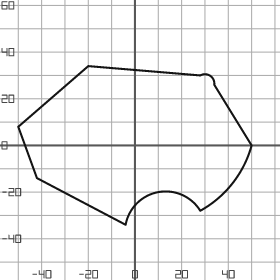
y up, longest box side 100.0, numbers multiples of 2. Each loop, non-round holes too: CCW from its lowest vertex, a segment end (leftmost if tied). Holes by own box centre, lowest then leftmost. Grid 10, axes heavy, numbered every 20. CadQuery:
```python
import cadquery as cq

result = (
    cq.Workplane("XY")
    .moveTo(-4.0, -34.0)
    .threePointArc((10.0, -20.0), (28.0, -28.0))
    .threePointArc((42.0, -16.0), (50.0, 0.0))
    .lineTo(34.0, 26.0)
    .threePointArc((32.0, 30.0), (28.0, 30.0))
    .lineTo(-20.0, 34.0)
    .lineTo(-50.0, 8.0)
    .lineTo(-42.0, -14.0)
    .close()
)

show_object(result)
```